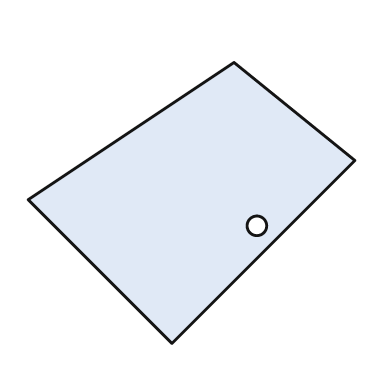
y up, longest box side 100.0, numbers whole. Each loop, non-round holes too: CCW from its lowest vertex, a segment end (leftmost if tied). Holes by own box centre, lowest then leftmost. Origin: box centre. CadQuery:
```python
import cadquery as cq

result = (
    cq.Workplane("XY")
    .moveTo(-6.0, -43.0)
    .lineTo(50.0, 13.0)
    .lineTo(13.0, 43.0)
    .lineTo(-50.0, 1.0)
    .close()
    .moveTo(20.0, -7.0)
    .circle(3.0)
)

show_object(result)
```